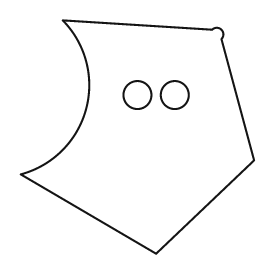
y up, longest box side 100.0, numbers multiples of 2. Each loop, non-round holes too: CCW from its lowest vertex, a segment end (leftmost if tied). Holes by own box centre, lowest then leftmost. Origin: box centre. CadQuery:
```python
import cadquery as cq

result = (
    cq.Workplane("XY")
    .moveTo(8.0, -50.0)
    .lineTo(50.0, -10.0)
    .lineTo(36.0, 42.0)
    .threePointArc((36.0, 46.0), (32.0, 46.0))
    .lineTo(-32.0, 50.0)
    .threePointArc((-22.0, 12.0), (-50.0, -16.0))
    .close()
    .moveTo(0.0, 18.0)
    .circle(6.0)
    .moveTo(16.0, 18.0)
    .circle(6.0)
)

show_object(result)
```